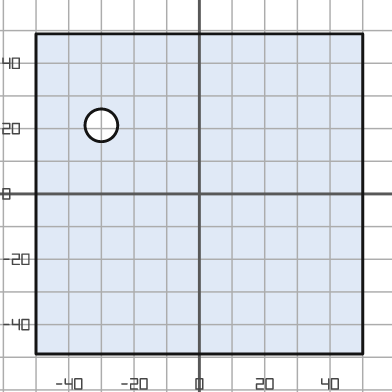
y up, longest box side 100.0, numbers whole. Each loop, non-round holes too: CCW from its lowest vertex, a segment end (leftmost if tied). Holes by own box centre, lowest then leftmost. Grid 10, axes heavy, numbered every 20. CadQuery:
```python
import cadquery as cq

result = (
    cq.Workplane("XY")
    .moveTo(-50.0, -49.0)
    .lineTo(50.0, -49.0)
    .lineTo(50.0, 49.0)
    .lineTo(-50.0, 49.0)
    .close()
    .moveTo(-30.0, 21.0)
    .circle(5.0)
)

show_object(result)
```